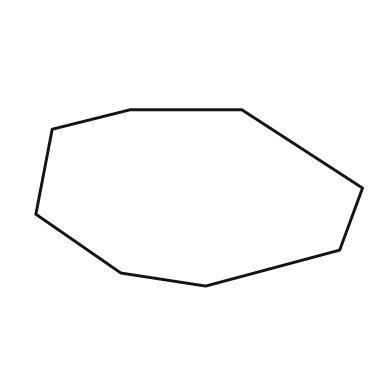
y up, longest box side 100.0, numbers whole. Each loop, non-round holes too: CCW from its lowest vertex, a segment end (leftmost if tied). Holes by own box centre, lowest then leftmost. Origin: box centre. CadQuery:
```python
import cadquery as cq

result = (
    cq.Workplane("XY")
    .moveTo(2.0, -27.0)
    .lineTo(43.0, -16.0)
    .lineTo(50.0, 3.0)
    .lineTo(13.0, 27.0)
    .lineTo(-21.0, 27.0)
    .lineTo(-45.0, 21.0)
    .lineTo(-50.0, -5.0)
    .lineTo(-24.0, -23.0)
    .close()
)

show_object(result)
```